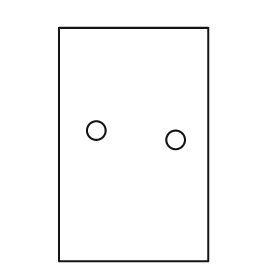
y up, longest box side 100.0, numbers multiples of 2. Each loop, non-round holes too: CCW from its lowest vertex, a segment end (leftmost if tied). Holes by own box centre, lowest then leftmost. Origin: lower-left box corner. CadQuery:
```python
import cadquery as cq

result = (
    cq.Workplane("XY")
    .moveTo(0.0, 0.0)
    .lineTo(64.0, 0.0)
    .lineTo(64.0, 100.0)
    .lineTo(0.0, 100.0)
    .close()
    .moveTo(50.0, 52.0)
    .circle(4.0)
    .moveTo(16.0, 56.0)
    .circle(4.0)
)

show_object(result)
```